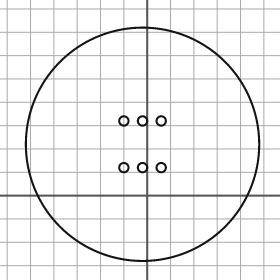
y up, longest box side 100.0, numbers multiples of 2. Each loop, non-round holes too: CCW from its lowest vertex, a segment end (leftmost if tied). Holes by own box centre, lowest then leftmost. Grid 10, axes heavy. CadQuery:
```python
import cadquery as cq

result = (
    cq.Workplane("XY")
    .moveTo(-2.0, 22.0)
    .circle(50.0)
    .moveTo(-10.0, 12.0)
    .circle(2.0)
    .moveTo(-2.0, 12.0)
    .circle(2.0)
    .moveTo(6.0, 12.0)
    .circle(2.0)
    .moveTo(-10.0, 32.0)
    .circle(2.0)
    .moveTo(-2.0, 32.0)
    .circle(2.0)
    .moveTo(6.0, 32.0)
    .circle(2.0)
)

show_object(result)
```